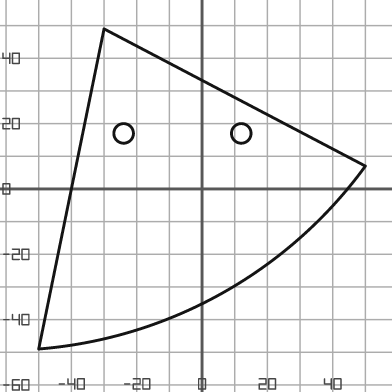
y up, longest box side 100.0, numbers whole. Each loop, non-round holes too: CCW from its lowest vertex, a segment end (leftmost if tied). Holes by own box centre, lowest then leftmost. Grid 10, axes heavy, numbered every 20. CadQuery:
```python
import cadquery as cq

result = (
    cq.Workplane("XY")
    .moveTo(-50.0, -49.0)
    .threePointArc((6.0, -32.0), (50.0, 7.0))
    .lineTo(-30.0, 49.0)
    .close()
    .moveTo(-24.0, 17.0)
    .circle(3.0)
    .moveTo(12.0, 17.0)
    .circle(3.0)
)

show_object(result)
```